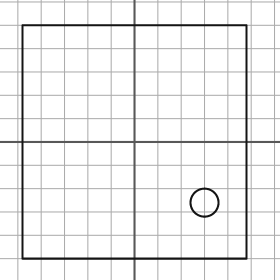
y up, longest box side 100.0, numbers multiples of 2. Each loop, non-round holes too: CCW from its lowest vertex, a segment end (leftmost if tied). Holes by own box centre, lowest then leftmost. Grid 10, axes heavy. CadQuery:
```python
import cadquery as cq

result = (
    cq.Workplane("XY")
    .moveTo(-48.0, -50.0)
    .lineTo(48.0, -50.0)
    .lineTo(48.0, 50.0)
    .lineTo(-48.0, 50.0)
    .close()
    .moveTo(30.0, -26.0)
    .circle(6.0)
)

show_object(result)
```